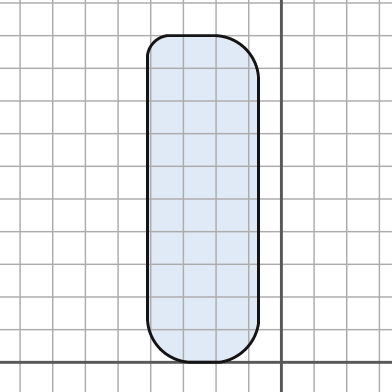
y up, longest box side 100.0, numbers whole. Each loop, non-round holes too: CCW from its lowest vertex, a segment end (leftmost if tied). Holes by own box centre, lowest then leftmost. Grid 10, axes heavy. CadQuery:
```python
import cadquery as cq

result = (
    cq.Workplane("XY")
    .moveTo(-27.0, 0.0)
    .lineTo(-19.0, 0.0)
    .threePointArc((-11.0, 4.0), (-7.0, 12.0))
    .lineTo(-7.0, 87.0)
    .threePointArc((-11.0, 96.0), (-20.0, 100.0))
    .lineTo(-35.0, 100.0)
    .threePointArc((-39.0, 98.0), (-41.0, 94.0))
    .lineTo(-41.0, 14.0)
    .threePointArc((-37.0, 4.0), (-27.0, 0.0))
    .close()
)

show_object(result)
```